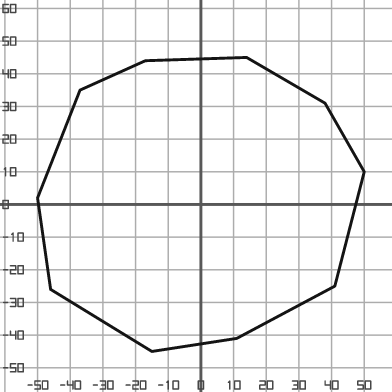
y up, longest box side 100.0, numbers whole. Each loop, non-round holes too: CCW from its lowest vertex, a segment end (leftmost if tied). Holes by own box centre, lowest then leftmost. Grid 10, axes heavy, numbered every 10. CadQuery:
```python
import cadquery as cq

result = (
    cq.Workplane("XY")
    .moveTo(-15.0, -45.0)
    .lineTo(11.0, -41.0)
    .lineTo(41.0, -25.0)
    .lineTo(50.0, 10.0)
    .lineTo(38.0, 31.0)
    .lineTo(14.0, 45.0)
    .lineTo(-17.0, 44.0)
    .lineTo(-37.0, 35.0)
    .lineTo(-50.0, 2.0)
    .lineTo(-46.0, -26.0)
    .close()
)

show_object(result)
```